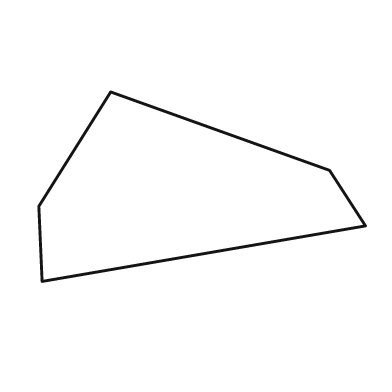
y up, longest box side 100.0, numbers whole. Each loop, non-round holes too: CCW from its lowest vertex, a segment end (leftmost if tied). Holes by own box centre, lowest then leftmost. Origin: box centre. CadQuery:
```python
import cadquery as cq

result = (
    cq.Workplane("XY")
    .moveTo(-49.0, -29.0)
    .lineTo(50.0, -12.0)
    .lineTo(39.0, 5.0)
    .lineTo(-28.0, 29.0)
    .lineTo(-50.0, -6.0)
    .close()
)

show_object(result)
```